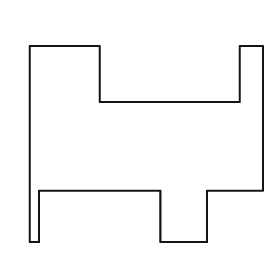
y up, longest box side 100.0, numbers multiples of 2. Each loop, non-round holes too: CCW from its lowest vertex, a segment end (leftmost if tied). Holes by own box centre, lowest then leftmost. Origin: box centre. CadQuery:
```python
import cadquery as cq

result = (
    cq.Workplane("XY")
    .moveTo(-50.0, -42.0)
    .lineTo(-46.0, -42.0)
    .lineTo(-46.0, -20.0)
    .lineTo(6.0, -20.0)
    .lineTo(6.0, -42.0)
    .lineTo(26.0, -42.0)
    .lineTo(26.0, -20.0)
    .lineTo(50.0, -20.0)
    .lineTo(50.0, 42.0)
    .lineTo(40.0, 42.0)
    .lineTo(40.0, 18.0)
    .lineTo(-20.0, 18.0)
    .lineTo(-20.0, 42.0)
    .lineTo(-50.0, 42.0)
    .close()
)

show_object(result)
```